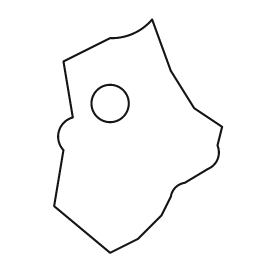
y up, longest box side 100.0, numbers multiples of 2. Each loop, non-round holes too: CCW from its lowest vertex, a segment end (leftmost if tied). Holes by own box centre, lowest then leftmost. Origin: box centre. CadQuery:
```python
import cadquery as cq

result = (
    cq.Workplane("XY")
    .moveTo(-12.0, -50.0)
    .lineTo(0.0, -44.0)
    .lineTo(10.0, -34.0)
    .lineTo(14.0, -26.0)
    .threePointArc((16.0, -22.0), (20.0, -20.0))
    .lineTo(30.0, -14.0)
    .threePointArc((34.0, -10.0), (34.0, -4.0))
    .lineTo(36.0, 4.0)
    .lineTo(24.0, 12.0)
    .lineTo(14.0, 28.0)
    .lineTo(6.0, 50.0)
    .threePointArc((-2.0, 44.0), (-12.0, 42.0))
    .lineTo(-32.0, 32.0)
    .lineTo(-28.0, 8.0)
    .threePointArc((-34.0, 2.0), (-32.0, -6.0))
    .lineTo(-36.0, -30.0)
    .close()
    .moveTo(-12.0, 14.0)
    .circle(8.0)
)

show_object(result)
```